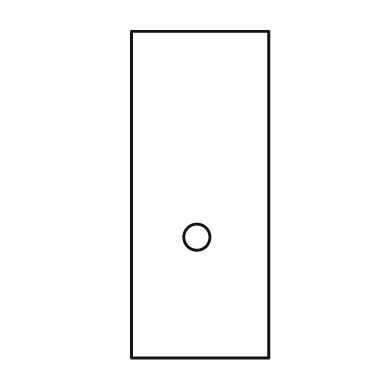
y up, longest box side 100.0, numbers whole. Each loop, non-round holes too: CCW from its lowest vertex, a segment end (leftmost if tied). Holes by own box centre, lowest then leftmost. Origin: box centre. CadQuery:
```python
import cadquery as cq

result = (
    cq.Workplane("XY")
    .moveTo(-21.0, -50.0)
    .lineTo(21.0, -50.0)
    .lineTo(21.0, 50.0)
    .lineTo(-21.0, 50.0)
    .close()
    .moveTo(-1.0, -13.0)
    .circle(4.0)
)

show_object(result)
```